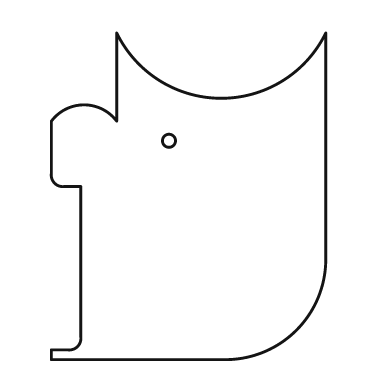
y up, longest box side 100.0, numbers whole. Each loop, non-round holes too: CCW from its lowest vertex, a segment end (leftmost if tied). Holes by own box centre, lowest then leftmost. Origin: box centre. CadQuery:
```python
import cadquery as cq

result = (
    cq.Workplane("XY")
    .moveTo(-42.0, -50.0)
    .lineTo(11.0, -50.0)
    .threePointArc((33.0, -41.0), (42.0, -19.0))
    .lineTo(42.0, 50.0)
    .threePointArc((10.0, 30.0), (-22.0, 50.0))
    .lineTo(-22.0, 23.0)
    .threePointArc((-32.0, 28.0), (-42.0, 23.0))
    .lineTo(-42.0, 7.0)
    .threePointArc((-41.0, 4.0), (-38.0, 3.0))
    .lineTo(-33.0, 3.0)
    .lineTo(-33.0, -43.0)
    .threePointArc((-34.0, -46.0), (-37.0, -47.0))
    .lineTo(-42.0, -47.0)
    .close()
    .moveTo(-6.0, 17.0)
    .circle(2.0)
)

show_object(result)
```